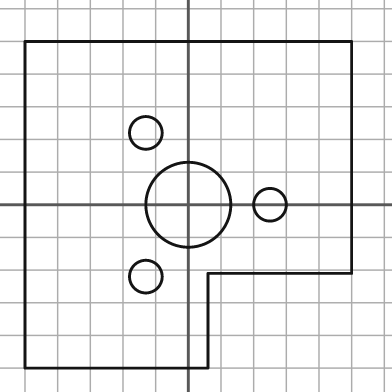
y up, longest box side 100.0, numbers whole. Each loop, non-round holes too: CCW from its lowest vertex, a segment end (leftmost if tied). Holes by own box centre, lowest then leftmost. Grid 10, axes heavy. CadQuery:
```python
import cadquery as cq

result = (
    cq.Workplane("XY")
    .moveTo(-50.0, -50.0)
    .lineTo(6.0, -50.0)
    .lineTo(6.0, -21.0)
    .lineTo(50.0, -21.0)
    .lineTo(50.0, 50.0)
    .lineTo(-50.0, 50.0)
    .close()
    .moveTo(-13.0, -22.0)
    .circle(5.0)
    .moveTo(0.0, 0.0)
    .circle(13.0)
    .moveTo(25.0, 0.0)
    .circle(5.0)
    .moveTo(-13.0, 22.0)
    .circle(5.0)
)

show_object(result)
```